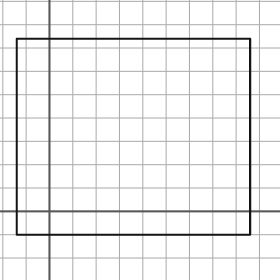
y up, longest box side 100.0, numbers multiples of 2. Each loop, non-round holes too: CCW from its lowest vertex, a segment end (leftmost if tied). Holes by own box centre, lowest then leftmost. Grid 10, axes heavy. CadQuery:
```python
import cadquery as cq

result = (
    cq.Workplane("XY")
    .moveTo(-14.0, -10.0)
    .lineTo(86.0, -10.0)
    .lineTo(86.0, 74.0)
    .lineTo(-14.0, 74.0)
    .close()
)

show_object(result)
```